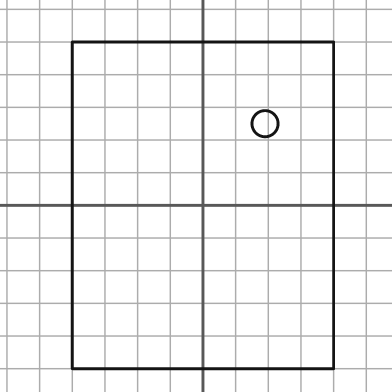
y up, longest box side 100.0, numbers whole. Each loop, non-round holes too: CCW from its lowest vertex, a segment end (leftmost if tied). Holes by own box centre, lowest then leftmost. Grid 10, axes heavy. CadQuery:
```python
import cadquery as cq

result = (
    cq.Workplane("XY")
    .moveTo(-40.0, -50.0)
    .lineTo(40.0, -50.0)
    .lineTo(40.0, 50.0)
    .lineTo(-40.0, 50.0)
    .close()
    .moveTo(19.0, 25.0)
    .circle(4.0)
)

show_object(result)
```